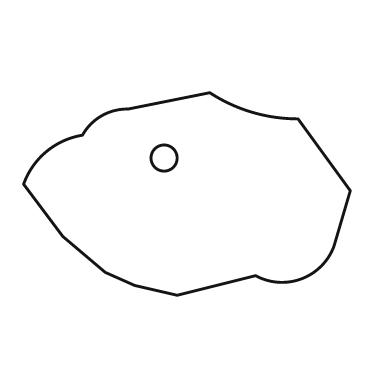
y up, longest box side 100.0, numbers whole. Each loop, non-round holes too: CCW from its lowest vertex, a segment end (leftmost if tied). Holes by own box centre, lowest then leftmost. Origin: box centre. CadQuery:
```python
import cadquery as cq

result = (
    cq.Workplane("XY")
    .moveTo(-3.0, -31.0)
    .lineTo(21.0, -25.0)
    .threePointArc((35.0, -26.0), (45.0, -16.0))
    .lineTo(50.0, 1.0)
    .lineTo(34.0, 23.0)
    .threePointArc((20.0, 25.0), (7.0, 31.0))
    .lineTo(-18.0, 26.0)
    .threePointArc((-26.0, 24.0), (-32.0, 18.0))
    .threePointArc((-43.0, 13.0), (-50.0, 3.0))
    .lineTo(-38.0, -13.0)
    .lineTo(-25.0, -24.0)
    .lineTo(-16.0, -28.0)
    .close()
    .moveTo(-7.0, 11.0)
    .circle(4.0)
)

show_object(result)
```